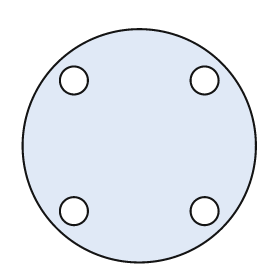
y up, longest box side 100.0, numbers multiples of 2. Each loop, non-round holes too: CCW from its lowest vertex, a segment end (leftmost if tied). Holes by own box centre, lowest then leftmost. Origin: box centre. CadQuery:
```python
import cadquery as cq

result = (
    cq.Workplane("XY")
    .moveTo(0.0, 0.0)
    .circle(50.0)
    .moveTo(-28.0, -28.0)
    .circle(6.0)
    .moveTo(28.0, -28.0)
    .circle(6.0)
    .moveTo(-28.0, 28.0)
    .circle(6.0)
    .moveTo(28.0, 28.0)
    .circle(6.0)
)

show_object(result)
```